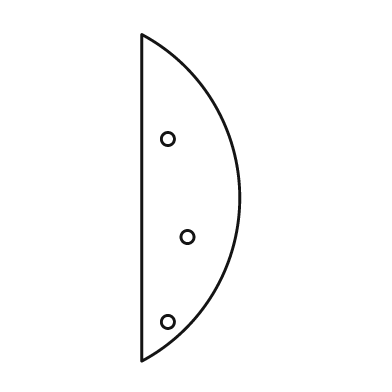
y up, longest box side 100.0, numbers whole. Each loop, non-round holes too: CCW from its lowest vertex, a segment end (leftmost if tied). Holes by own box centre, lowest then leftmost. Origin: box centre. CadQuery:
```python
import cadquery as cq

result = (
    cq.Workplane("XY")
    .moveTo(-15.0, -50.0)
    .threePointArc((15.0, 0.0), (-15.0, 50.0))
    .close()
    .moveTo(-7.0, -38.0)
    .circle(2.0)
    .moveTo(-1.0, -12.0)
    .circle(2.0)
    .moveTo(-7.0, 18.0)
    .circle(2.0)
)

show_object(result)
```